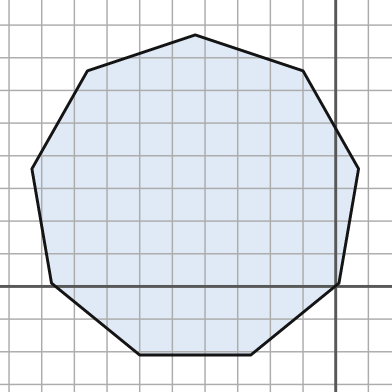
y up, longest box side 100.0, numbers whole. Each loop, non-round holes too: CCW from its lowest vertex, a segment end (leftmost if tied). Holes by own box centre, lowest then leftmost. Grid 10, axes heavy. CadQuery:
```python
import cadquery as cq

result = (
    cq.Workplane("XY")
    .moveTo(-60.0, -21.0)
    .lineTo(-26.0, -21.0)
    .lineTo(1.0, 1.0)
    .lineTo(7.0, 36.0)
    .lineTo(-10.0, 66.0)
    .lineTo(-43.0, 77.0)
    .lineTo(-76.0, 66.0)
    .lineTo(-93.0, 36.0)
    .lineTo(-87.0, 1.0)
    .close()
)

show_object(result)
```